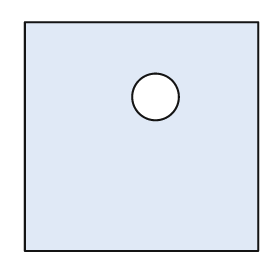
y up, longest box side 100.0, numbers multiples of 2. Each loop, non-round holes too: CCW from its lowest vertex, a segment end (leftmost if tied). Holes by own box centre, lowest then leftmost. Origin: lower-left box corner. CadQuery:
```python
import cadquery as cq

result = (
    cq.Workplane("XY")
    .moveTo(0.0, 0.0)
    .lineTo(100.0, 0.0)
    .lineTo(100.0, 98.0)
    .lineTo(0.0, 98.0)
    .close()
    .moveTo(56.0, 66.0)
    .circle(10.0)
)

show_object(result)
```